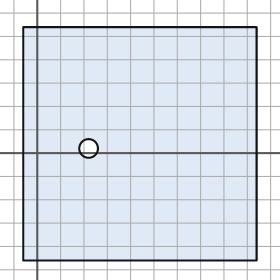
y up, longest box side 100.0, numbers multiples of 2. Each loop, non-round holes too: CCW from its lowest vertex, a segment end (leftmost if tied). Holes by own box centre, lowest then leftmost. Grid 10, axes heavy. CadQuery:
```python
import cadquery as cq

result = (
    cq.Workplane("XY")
    .moveTo(-6.0, -46.0)
    .lineTo(94.0, -46.0)
    .lineTo(94.0, 54.0)
    .lineTo(-6.0, 54.0)
    .close()
    .moveTo(22.0, 2.0)
    .circle(4.0)
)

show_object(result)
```